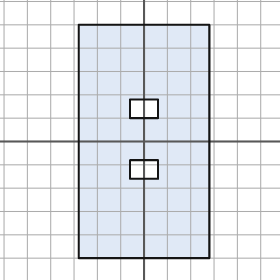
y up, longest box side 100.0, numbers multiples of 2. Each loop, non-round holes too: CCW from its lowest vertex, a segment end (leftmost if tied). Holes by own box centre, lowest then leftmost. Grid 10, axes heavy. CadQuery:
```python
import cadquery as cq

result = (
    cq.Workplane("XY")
    .moveTo(-28.0, -50.0)
    .lineTo(28.0, -50.0)
    .lineTo(28.0, 50.0)
    .lineTo(-28.0, 50.0)
    .close()
    .moveTo(-6.0, -16.0)
    .lineTo(6.0, -16.0)
    .lineTo(6.0, -8.0)
    .lineTo(-6.0, -8.0)
    .close()
    .moveTo(-6.0, 10.0)
    .lineTo(6.0, 10.0)
    .lineTo(6.0, 18.0)
    .lineTo(-6.0, 18.0)
    .close()
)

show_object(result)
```